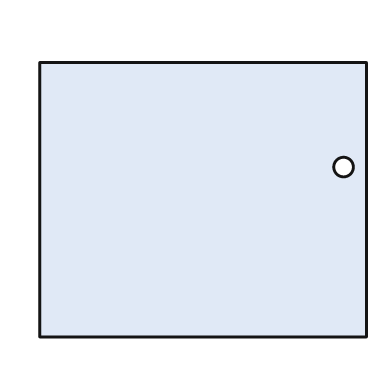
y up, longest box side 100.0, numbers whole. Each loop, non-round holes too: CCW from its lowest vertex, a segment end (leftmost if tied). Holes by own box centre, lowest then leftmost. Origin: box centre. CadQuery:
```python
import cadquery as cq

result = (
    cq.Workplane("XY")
    .moveTo(-50.0, -42.0)
    .lineTo(50.0, -42.0)
    .lineTo(50.0, 42.0)
    .lineTo(-50.0, 42.0)
    .close()
    .moveTo(43.0, 10.0)
    .circle(3.0)
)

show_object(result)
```